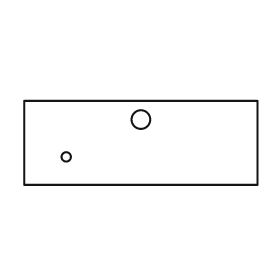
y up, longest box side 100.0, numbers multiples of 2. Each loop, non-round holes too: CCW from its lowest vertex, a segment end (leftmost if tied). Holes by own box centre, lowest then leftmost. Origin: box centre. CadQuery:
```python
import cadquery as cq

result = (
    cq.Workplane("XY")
    .moveTo(-50.0, -18.0)
    .lineTo(50.0, -18.0)
    .lineTo(50.0, 18.0)
    .lineTo(-50.0, 18.0)
    .close()
    .moveTo(-32.0, -6.0)
    .circle(2.0)
    .moveTo(0.0, 10.0)
    .circle(4.0)
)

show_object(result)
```